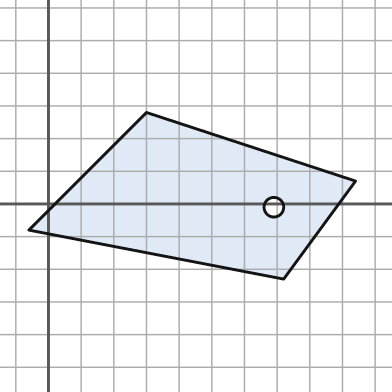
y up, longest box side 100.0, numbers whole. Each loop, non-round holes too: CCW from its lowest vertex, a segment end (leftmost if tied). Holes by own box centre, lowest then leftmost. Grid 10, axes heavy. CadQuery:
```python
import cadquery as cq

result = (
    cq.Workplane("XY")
    .moveTo(72.0, -23.0)
    .lineTo(94.0, 7.0)
    .lineTo(30.0, 28.0)
    .lineTo(-6.0, -8.0)
    .close()
    .moveTo(69.0, -1.0)
    .circle(3.0)
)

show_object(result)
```